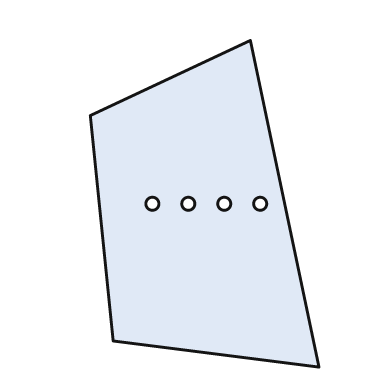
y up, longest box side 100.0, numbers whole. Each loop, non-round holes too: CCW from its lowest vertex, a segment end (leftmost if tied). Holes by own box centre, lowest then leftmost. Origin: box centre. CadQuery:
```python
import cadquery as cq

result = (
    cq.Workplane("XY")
    .moveTo(35.0, -50.0)
    .lineTo(14.0, 50.0)
    .lineTo(-35.0, 27.0)
    .lineTo(-28.0, -42.0)
    .close()
    .moveTo(-16.0, 0.0)
    .circle(2.0)
    .moveTo(-5.0, 0.0)
    .circle(2.0)
    .moveTo(6.0, 0.0)
    .circle(2.0)
    .moveTo(17.0, 0.0)
    .circle(2.0)
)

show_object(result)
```